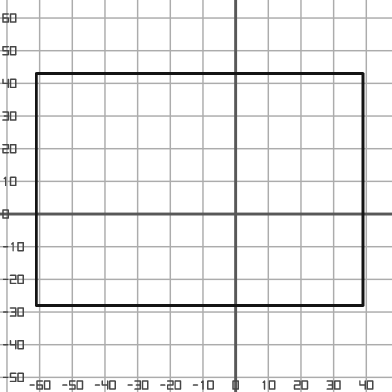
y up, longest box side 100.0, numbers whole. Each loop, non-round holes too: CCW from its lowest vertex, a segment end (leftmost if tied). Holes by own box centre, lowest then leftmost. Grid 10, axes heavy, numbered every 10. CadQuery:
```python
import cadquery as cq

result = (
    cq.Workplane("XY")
    .moveTo(-61.0, -28.0)
    .lineTo(39.0, -28.0)
    .lineTo(39.0, 43.0)
    .lineTo(-61.0, 43.0)
    .close()
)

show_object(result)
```